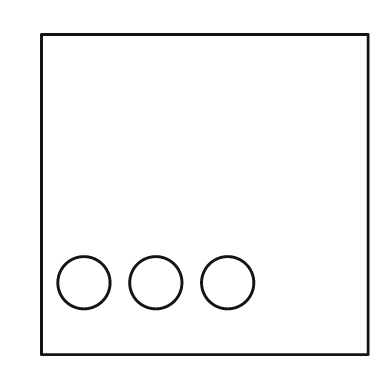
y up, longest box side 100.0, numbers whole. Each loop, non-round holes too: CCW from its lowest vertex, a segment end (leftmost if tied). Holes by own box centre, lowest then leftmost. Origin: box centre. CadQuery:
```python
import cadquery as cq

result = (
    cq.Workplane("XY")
    .moveTo(-50.0, -49.0)
    .lineTo(50.0, -49.0)
    .lineTo(50.0, 49.0)
    .lineTo(-50.0, 49.0)
    .close()
    .moveTo(-37.0, -27.0)
    .circle(8.0)
    .moveTo(-15.0, -27.0)
    .circle(8.0)
    .moveTo(7.0, -27.0)
    .circle(8.0)
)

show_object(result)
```